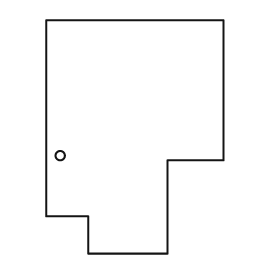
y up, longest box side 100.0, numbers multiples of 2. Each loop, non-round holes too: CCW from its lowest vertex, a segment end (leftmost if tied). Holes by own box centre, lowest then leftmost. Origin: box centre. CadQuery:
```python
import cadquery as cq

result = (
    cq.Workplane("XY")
    .moveTo(-20.0, -50.0)
    .lineTo(14.0, -50.0)
    .lineTo(14.0, -10.0)
    .lineTo(38.0, -10.0)
    .lineTo(38.0, 50.0)
    .lineTo(-38.0, 50.0)
    .lineTo(-38.0, -34.0)
    .lineTo(-20.0, -34.0)
    .close()
    .moveTo(-32.0, -8.0)
    .circle(2.0)
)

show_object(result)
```